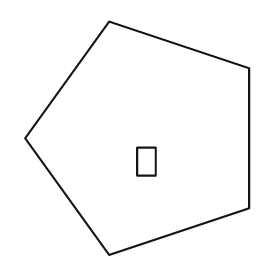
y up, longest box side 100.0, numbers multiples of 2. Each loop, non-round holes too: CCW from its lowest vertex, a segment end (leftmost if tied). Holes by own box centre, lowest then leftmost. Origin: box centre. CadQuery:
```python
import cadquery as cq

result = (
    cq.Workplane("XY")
    .moveTo(-12.0, -50.0)
    .lineTo(48.0, -30.0)
    .lineTo(48.0, 30.0)
    .lineTo(-12.0, 50.0)
    .lineTo(-48.0, 0.0)
    .close()
    .moveTo(0.0, -16.0)
    .lineTo(8.0, -16.0)
    .lineTo(8.0, -4.0)
    .lineTo(0.0, -4.0)
    .close()
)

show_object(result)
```